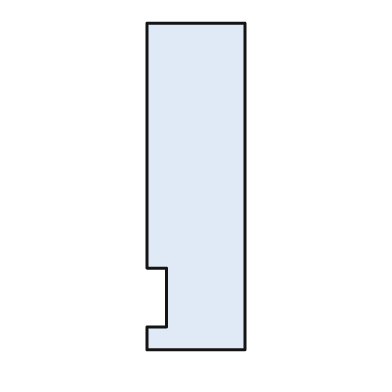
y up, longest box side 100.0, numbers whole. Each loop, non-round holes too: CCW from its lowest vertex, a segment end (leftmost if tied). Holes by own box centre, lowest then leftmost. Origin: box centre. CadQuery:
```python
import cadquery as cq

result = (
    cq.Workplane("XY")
    .moveTo(-15.0, -50.0)
    .lineTo(15.0, -50.0)
    .lineTo(15.0, 50.0)
    .lineTo(-15.0, 50.0)
    .lineTo(-15.0, -25.0)
    .lineTo(-9.0, -25.0)
    .lineTo(-9.0, -43.0)
    .lineTo(-15.0, -43.0)
    .close()
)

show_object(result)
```